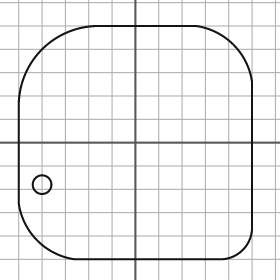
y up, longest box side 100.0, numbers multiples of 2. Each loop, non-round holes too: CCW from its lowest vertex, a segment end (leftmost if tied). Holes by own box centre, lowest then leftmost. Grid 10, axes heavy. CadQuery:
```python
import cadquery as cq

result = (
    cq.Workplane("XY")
    .moveTo(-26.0, -50.0)
    .lineTo(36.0, -50.0)
    .threePointArc((46.0, -46.0), (50.0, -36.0))
    .lineTo(50.0, 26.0)
    .threePointArc((42.0, 42.0), (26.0, 50.0))
    .lineTo(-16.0, 50.0)
    .threePointArc((-40.0, 40.0), (-50.0, 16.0))
    .lineTo(-50.0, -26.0)
    .threePointArc((-42.0, -42.0), (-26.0, -50.0))
    .close()
    .moveTo(-40.0, -18.0)
    .circle(4.0)
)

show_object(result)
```